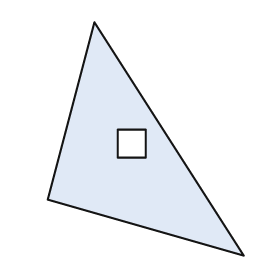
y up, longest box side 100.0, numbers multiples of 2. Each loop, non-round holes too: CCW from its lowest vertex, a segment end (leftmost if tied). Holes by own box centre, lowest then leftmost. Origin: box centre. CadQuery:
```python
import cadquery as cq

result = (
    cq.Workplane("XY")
    .moveTo(42.0, -50.0)
    .lineTo(-22.0, 50.0)
    .lineTo(-42.0, -26.0)
    .close()
    .moveTo(-12.0, -8.0)
    .lineTo(0.0, -8.0)
    .lineTo(0.0, 4.0)
    .lineTo(-12.0, 4.0)
    .close()
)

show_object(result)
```